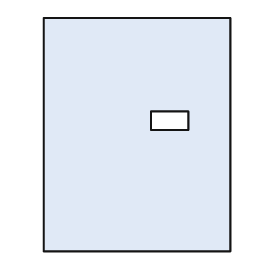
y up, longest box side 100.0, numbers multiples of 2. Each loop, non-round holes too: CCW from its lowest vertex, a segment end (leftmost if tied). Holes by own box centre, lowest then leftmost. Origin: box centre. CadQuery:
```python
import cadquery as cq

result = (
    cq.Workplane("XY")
    .moveTo(-40.0, -50.0)
    .lineTo(40.0, -50.0)
    .lineTo(40.0, 50.0)
    .lineTo(-40.0, 50.0)
    .close()
    .moveTo(6.0, 2.0)
    .lineTo(22.0, 2.0)
    .lineTo(22.0, 10.0)
    .lineTo(6.0, 10.0)
    .close()
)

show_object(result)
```